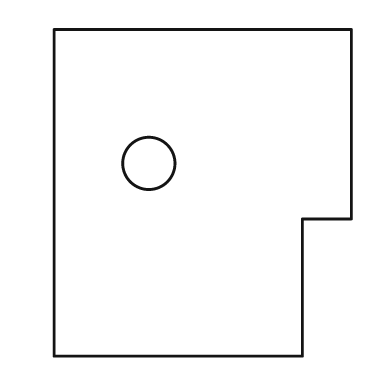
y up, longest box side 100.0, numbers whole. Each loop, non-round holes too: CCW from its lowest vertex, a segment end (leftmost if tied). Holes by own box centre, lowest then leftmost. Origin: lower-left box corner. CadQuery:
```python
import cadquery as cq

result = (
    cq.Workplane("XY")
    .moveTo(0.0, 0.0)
    .lineTo(76.0, 0.0)
    .lineTo(76.0, 42.0)
    .lineTo(91.0, 42.0)
    .lineTo(91.0, 100.0)
    .lineTo(0.0, 100.0)
    .close()
    .moveTo(29.0, 59.0)
    .circle(8.0)
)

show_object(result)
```